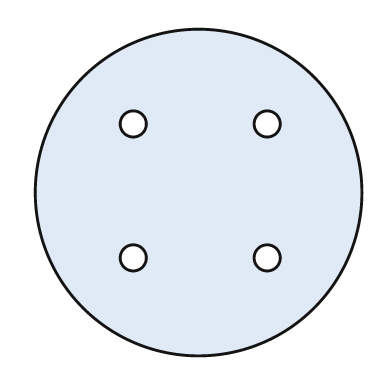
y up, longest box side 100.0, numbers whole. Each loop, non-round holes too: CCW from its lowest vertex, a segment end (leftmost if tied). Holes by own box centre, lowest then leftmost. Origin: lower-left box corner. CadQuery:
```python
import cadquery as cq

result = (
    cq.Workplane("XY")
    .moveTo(50.0, 50.0)
    .circle(50.0)
    .moveTo(30.0, 30.0)
    .circle(4.0)
    .moveTo(71.0, 30.0)
    .circle(4.0)
    .moveTo(30.0, 71.0)
    .circle(4.0)
    .moveTo(71.0, 71.0)
    .circle(4.0)
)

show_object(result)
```